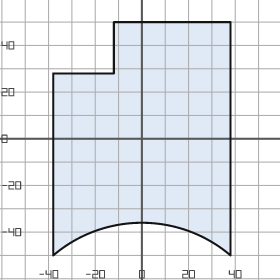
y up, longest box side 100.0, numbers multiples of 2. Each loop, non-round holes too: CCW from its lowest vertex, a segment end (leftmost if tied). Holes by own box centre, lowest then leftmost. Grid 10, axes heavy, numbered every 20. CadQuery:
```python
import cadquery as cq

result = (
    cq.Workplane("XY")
    .moveTo(-38.0, -50.0)
    .threePointArc((0.0, -36.0), (38.0, -50.0))
    .lineTo(38.0, 50.0)
    .lineTo(-12.0, 50.0)
    .lineTo(-12.0, 28.0)
    .lineTo(-38.0, 28.0)
    .close()
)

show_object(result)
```